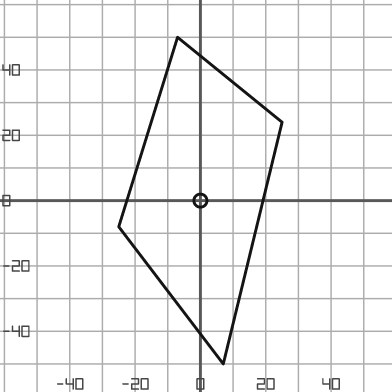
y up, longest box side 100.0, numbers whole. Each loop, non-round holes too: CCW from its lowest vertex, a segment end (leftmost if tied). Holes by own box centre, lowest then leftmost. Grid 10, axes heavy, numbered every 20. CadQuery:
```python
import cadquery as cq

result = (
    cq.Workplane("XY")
    .moveTo(7.0, -50.0)
    .lineTo(25.0, 24.0)
    .lineTo(-7.0, 50.0)
    .lineTo(-25.0, -8.0)
    .close()
    .moveTo(0.0, 0.0)
    .circle(2.0)
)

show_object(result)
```